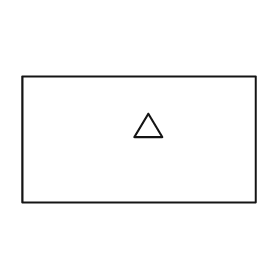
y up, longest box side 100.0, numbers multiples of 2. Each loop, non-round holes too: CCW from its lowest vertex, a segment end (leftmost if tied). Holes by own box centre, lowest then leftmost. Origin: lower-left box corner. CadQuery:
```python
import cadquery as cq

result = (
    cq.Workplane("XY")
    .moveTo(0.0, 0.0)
    .lineTo(100.0, 0.0)
    .lineTo(100.0, 54.0)
    .lineTo(0.0, 54.0)
    .close()
    .moveTo(48.0, 28.0)
    .lineTo(60.0, 28.0)
    .lineTo(54.0, 38.0)
    .close()
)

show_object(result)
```